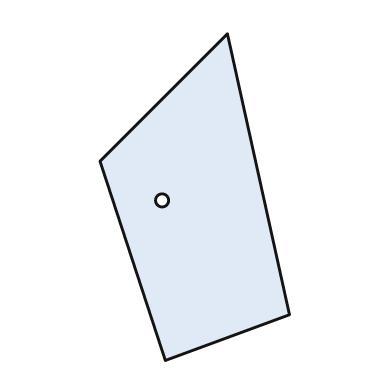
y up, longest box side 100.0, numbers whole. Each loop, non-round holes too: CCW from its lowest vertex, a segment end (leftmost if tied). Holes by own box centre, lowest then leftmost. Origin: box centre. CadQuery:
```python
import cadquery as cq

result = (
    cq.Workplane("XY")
    .moveTo(-9.0, -50.0)
    .lineTo(29.0, -36.0)
    .lineTo(10.0, 50.0)
    .lineTo(-29.0, 11.0)
    .close()
    .moveTo(-10.0, -1.0)
    .circle(2.0)
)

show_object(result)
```